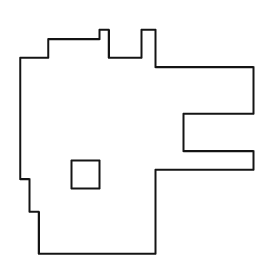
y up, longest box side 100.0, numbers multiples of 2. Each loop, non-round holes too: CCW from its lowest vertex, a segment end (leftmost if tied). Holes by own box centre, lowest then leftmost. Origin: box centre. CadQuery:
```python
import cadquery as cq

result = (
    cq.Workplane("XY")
    .moveTo(-42.0, -48.0)
    .lineTo(8.0, -48.0)
    .lineTo(8.0, -12.0)
    .lineTo(50.0, -12.0)
    .lineTo(50.0, -4.0)
    .lineTo(20.0, -4.0)
    .lineTo(20.0, 12.0)
    .lineTo(50.0, 12.0)
    .lineTo(50.0, 32.0)
    .lineTo(8.0, 32.0)
    .lineTo(8.0, 48.0)
    .lineTo(2.0, 48.0)
    .lineTo(2.0, 36.0)
    .lineTo(-12.0, 36.0)
    .lineTo(-12.0, 48.0)
    .lineTo(-16.0, 48.0)
    .lineTo(-16.0, 44.0)
    .lineTo(-38.0, 44.0)
    .lineTo(-38.0, 36.0)
    .lineTo(-50.0, 36.0)
    .lineTo(-50.0, -16.0)
    .lineTo(-46.0, -16.0)
    .lineTo(-46.0, -30.0)
    .lineTo(-42.0, -30.0)
    .close()
    .moveTo(-28.0, -20.0)
    .lineTo(-16.0, -20.0)
    .lineTo(-16.0, -8.0)
    .lineTo(-28.0, -8.0)
    .close()
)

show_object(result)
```